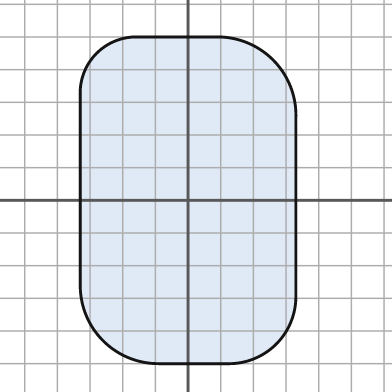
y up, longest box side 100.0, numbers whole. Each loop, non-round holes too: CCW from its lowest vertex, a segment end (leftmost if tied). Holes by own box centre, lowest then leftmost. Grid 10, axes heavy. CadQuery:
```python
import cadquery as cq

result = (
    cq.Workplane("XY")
    .moveTo(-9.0, -50.0)
    .lineTo(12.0, -50.0)
    .threePointArc((27.0, -44.0), (33.0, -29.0))
    .lineTo(33.0, 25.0)
    .threePointArc((26.0, 43.0), (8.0, 50.0))
    .lineTo(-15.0, 50.0)
    .threePointArc((-28.0, 45.0), (-33.0, 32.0))
    .lineTo(-33.0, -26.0)
    .threePointArc((-26.0, -43.0), (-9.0, -50.0))
    .close()
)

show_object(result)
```